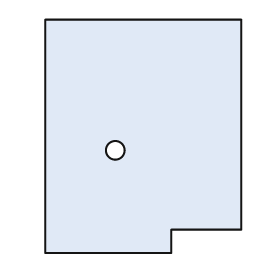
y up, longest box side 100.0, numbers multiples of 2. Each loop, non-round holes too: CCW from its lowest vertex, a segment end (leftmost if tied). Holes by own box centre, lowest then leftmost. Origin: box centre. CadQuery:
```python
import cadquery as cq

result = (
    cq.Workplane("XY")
    .moveTo(-42.0, -50.0)
    .lineTo(12.0, -50.0)
    .lineTo(12.0, -40.0)
    .lineTo(42.0, -40.0)
    .lineTo(42.0, 50.0)
    .lineTo(-42.0, 50.0)
    .close()
    .moveTo(-12.0, -6.0)
    .circle(4.0)
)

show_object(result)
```